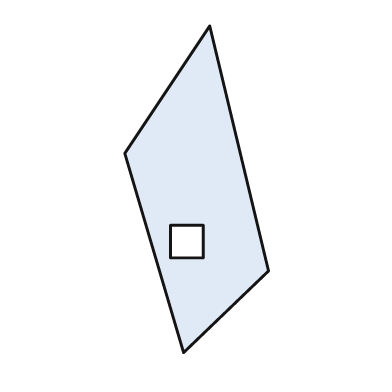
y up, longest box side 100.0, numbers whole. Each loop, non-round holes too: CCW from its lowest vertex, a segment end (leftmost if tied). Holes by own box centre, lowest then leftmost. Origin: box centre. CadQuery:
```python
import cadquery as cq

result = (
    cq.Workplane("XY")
    .moveTo(-4.0, -50.0)
    .lineTo(22.0, -25.0)
    .lineTo(4.0, 50.0)
    .lineTo(-22.0, 11.0)
    .close()
    .moveTo(-8.0, -21.0)
    .lineTo(2.0, -21.0)
    .lineTo(2.0, -11.0)
    .lineTo(-8.0, -11.0)
    .close()
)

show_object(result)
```